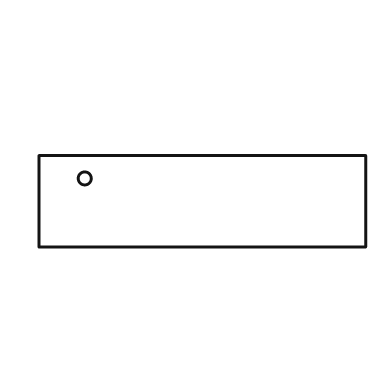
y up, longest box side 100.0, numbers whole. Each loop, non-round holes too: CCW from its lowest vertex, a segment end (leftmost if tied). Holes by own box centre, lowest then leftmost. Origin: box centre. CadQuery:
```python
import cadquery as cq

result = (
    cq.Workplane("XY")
    .moveTo(-50.0, -14.0)
    .lineTo(50.0, -14.0)
    .lineTo(50.0, 14.0)
    .lineTo(-50.0, 14.0)
    .close()
    .moveTo(-36.0, 7.0)
    .circle(2.0)
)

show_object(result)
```